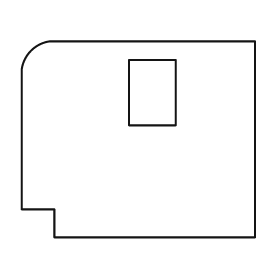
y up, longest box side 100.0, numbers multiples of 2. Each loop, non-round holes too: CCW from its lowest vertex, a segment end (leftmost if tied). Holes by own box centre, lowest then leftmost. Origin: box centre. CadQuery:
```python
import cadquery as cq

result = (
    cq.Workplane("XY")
    .moveTo(-36.0, -42.0)
    .lineTo(50.0, -42.0)
    .lineTo(50.0, 42.0)
    .lineTo(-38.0, 42.0)
    .threePointArc((-46.0, 38.0), (-50.0, 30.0))
    .lineTo(-50.0, -30.0)
    .lineTo(-36.0, -30.0)
    .close()
    .moveTo(-4.0, 6.0)
    .lineTo(16.0, 6.0)
    .lineTo(16.0, 34.0)
    .lineTo(-4.0, 34.0)
    .close()
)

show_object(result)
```